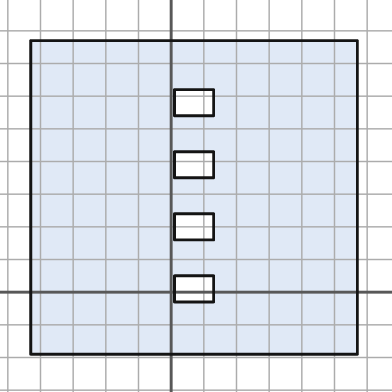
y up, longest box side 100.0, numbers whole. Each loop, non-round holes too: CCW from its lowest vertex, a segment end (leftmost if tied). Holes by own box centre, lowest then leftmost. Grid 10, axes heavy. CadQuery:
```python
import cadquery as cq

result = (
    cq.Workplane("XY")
    .moveTo(-43.0, -19.0)
    .lineTo(57.0, -19.0)
    .lineTo(57.0, 77.0)
    .lineTo(-43.0, 77.0)
    .close()
    .moveTo(1.0, -3.0)
    .lineTo(13.0, -3.0)
    .lineTo(13.0, 5.0)
    .lineTo(1.0, 5.0)
    .close()
    .moveTo(1.0, 16.0)
    .lineTo(13.0, 16.0)
    .lineTo(13.0, 24.0)
    .lineTo(1.0, 24.0)
    .close()
    .moveTo(1.0, 35.0)
    .lineTo(13.0, 35.0)
    .lineTo(13.0, 43.0)
    .lineTo(1.0, 43.0)
    .close()
    .moveTo(1.0, 54.0)
    .lineTo(13.0, 54.0)
    .lineTo(13.0, 62.0)
    .lineTo(1.0, 62.0)
    .close()
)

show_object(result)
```